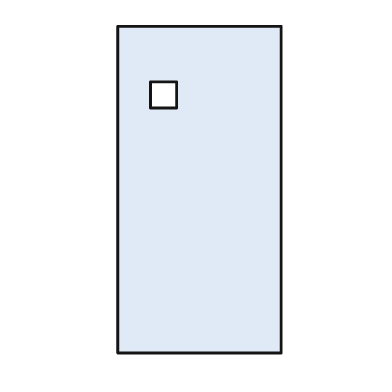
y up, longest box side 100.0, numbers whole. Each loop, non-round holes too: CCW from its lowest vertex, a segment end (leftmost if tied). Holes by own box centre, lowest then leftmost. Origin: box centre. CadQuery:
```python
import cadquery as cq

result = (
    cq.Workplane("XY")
    .moveTo(-25.0, -50.0)
    .lineTo(25.0, -50.0)
    .lineTo(25.0, 50.0)
    .lineTo(-25.0, 50.0)
    .close()
    .moveTo(-15.0, 25.0)
    .lineTo(-7.0, 25.0)
    .lineTo(-7.0, 33.0)
    .lineTo(-15.0, 33.0)
    .close()
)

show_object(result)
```